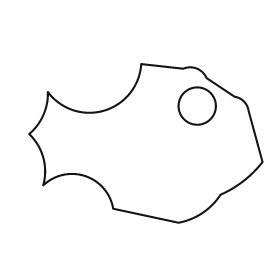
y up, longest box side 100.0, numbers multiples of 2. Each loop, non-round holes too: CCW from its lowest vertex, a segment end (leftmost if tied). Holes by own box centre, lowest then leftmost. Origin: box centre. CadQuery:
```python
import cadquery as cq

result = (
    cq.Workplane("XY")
    .moveTo(14.0, -34.0)
    .threePointArc((24.0, -30.0), (32.0, -22.0))
    .threePointArc((42.0, -16.0), (50.0, -8.0))
    .lineTo(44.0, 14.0)
    .threePointArc((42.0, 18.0), (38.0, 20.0))
    .lineTo(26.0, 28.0)
    .threePointArc((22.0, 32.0), (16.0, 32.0))
    .lineTo(-2.0, 34.0)
    .threePointArc((-18.0, 14.0), (-42.0, 22.0))
    .threePointArc((-44.0, 12.0), (-50.0, 4.0))
    .threePointArc((-44.0, -6.0), (-44.0, -18.0))
    .threePointArc((-26.0, -14.0), (-14.0, -28.0))
    .close()
    .moveTo(22.0, 16.0)
    .circle(8.0)
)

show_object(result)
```